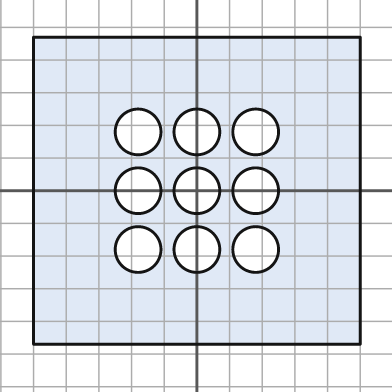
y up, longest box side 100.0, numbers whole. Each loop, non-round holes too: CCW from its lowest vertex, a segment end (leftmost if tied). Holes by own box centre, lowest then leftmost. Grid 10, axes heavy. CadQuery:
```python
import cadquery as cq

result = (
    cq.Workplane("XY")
    .moveTo(-50.0, -47.0)
    .lineTo(50.0, -47.0)
    .lineTo(50.0, 47.0)
    .lineTo(-50.0, 47.0)
    .close()
    .moveTo(-18.0, -18.0)
    .circle(7.0)
    .moveTo(0.0, -18.0)
    .circle(7.0)
    .moveTo(18.0, -18.0)
    .circle(7.0)
    .moveTo(-18.0, 0.0)
    .circle(7.0)
    .moveTo(0.0, 0.0)
    .circle(7.0)
    .moveTo(18.0, 0.0)
    .circle(7.0)
    .moveTo(-18.0, 18.0)
    .circle(7.0)
    .moveTo(0.0, 18.0)
    .circle(7.0)
    .moveTo(18.0, 18.0)
    .circle(7.0)
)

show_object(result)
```